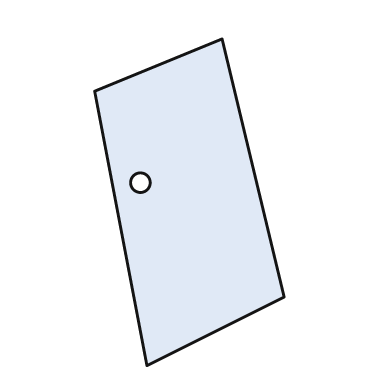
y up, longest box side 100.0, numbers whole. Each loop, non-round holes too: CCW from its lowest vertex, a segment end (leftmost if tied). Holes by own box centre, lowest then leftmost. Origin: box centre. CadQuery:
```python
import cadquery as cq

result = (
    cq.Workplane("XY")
    .moveTo(-13.0, -50.0)
    .lineTo(29.0, -29.0)
    .lineTo(10.0, 50.0)
    .lineTo(-29.0, 34.0)
    .close()
    .moveTo(-15.0, 6.0)
    .circle(3.0)
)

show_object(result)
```